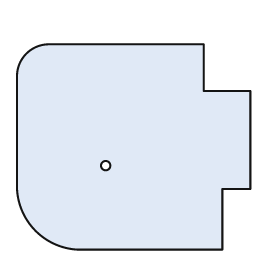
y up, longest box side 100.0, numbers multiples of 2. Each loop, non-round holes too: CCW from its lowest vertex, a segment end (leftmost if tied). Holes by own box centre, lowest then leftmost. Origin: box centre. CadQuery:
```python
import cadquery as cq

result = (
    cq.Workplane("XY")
    .moveTo(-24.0, -44.0)
    .lineTo(38.0, -44.0)
    .lineTo(38.0, -18.0)
    .lineTo(50.0, -18.0)
    .lineTo(50.0, 24.0)
    .lineTo(30.0, 24.0)
    .lineTo(30.0, 44.0)
    .lineTo(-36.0, 44.0)
    .threePointArc((-46.0, 40.0), (-50.0, 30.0))
    .lineTo(-50.0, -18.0)
    .threePointArc((-42.0, -36.0), (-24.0, -44.0))
    .close()
    .moveTo(-12.0, -8.0)
    .circle(2.0)
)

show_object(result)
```